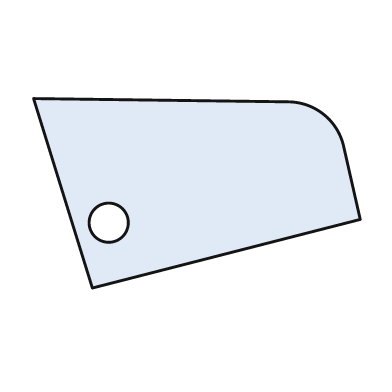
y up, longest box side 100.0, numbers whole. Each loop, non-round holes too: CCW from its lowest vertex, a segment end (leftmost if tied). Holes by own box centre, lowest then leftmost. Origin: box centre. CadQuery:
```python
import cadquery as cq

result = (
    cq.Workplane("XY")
    .moveTo(-32.0, -29.0)
    .lineTo(50.0, -8.0)
    .lineTo(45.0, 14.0)
    .threePointArc((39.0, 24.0), (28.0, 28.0))
    .lineTo(-50.0, 29.0)
    .close()
    .moveTo(-27.0, -9.0)
    .circle(6.0)
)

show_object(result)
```